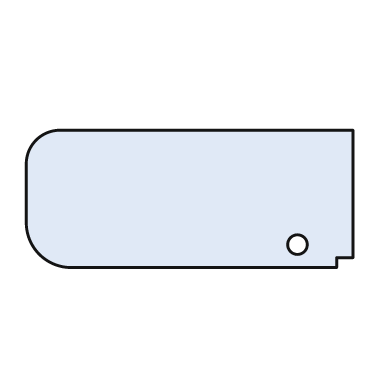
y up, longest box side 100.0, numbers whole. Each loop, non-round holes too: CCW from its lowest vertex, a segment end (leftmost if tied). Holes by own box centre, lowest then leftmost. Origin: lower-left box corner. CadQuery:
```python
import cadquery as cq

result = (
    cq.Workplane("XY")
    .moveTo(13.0, 0.0)
    .lineTo(95.0, 0.0)
    .lineTo(95.0, 3.0)
    .lineTo(100.0, 3.0)
    .lineTo(100.0, 42.0)
    .lineTo(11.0, 42.0)
    .threePointArc((3.0, 39.0), (0.0, 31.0))
    .lineTo(0.0, 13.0)
    .threePointArc((4.0, 4.0), (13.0, 0.0))
    .close()
    .moveTo(83.0, 7.0)
    .circle(3.0)
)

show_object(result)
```